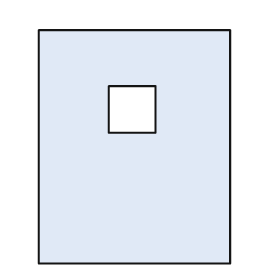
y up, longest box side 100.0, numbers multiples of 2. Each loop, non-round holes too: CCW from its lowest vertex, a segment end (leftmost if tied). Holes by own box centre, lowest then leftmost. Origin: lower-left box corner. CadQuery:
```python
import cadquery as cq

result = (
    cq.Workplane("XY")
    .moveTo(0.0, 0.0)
    .lineTo(82.0, 0.0)
    .lineTo(82.0, 100.0)
    .lineTo(0.0, 100.0)
    .close()
    .moveTo(30.0, 56.0)
    .lineTo(50.0, 56.0)
    .lineTo(50.0, 76.0)
    .lineTo(30.0, 76.0)
    .close()
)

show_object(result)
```